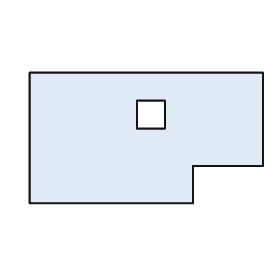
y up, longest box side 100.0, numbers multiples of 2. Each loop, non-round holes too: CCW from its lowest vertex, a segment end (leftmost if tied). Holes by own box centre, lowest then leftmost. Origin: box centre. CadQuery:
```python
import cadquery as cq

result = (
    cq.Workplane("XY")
    .moveTo(-50.0, -28.0)
    .lineTo(20.0, -28.0)
    .lineTo(20.0, -12.0)
    .lineTo(50.0, -12.0)
    .lineTo(50.0, 28.0)
    .lineTo(-50.0, 28.0)
    .close()
    .moveTo(-4.0, 4.0)
    .lineTo(8.0, 4.0)
    .lineTo(8.0, 16.0)
    .lineTo(-4.0, 16.0)
    .close()
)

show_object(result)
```